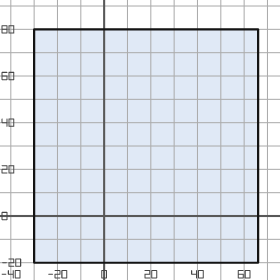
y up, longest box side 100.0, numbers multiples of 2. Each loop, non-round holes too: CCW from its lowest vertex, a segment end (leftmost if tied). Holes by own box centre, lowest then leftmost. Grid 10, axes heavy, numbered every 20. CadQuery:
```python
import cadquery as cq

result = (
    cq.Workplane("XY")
    .moveTo(-30.0, -20.0)
    .lineTo(66.0, -20.0)
    .lineTo(66.0, 80.0)
    .lineTo(-30.0, 80.0)
    .close()
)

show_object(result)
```